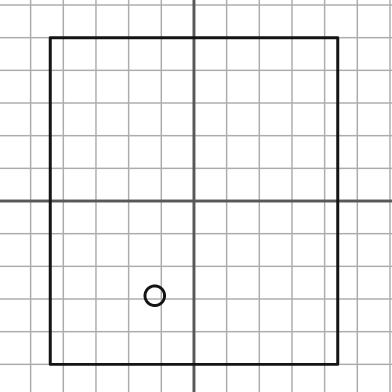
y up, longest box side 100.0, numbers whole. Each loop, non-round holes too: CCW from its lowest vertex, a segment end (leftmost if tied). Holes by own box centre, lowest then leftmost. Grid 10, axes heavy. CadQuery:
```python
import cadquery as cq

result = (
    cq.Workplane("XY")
    .moveTo(-44.0, -50.0)
    .lineTo(44.0, -50.0)
    .lineTo(44.0, 50.0)
    .lineTo(-44.0, 50.0)
    .close()
    .moveTo(-12.0, -29.0)
    .circle(3.0)
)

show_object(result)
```